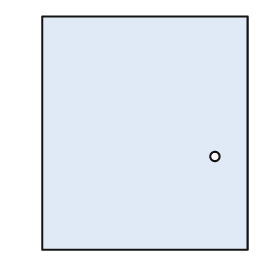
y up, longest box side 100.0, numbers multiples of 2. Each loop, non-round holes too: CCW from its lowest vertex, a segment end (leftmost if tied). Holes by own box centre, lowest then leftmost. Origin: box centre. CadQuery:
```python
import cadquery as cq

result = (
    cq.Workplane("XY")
    .moveTo(-44.0, -50.0)
    .lineTo(44.0, -50.0)
    .lineTo(44.0, 50.0)
    .lineTo(-44.0, 50.0)
    .close()
    .moveTo(30.0, -10.0)
    .circle(2.0)
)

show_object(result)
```